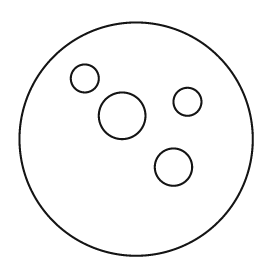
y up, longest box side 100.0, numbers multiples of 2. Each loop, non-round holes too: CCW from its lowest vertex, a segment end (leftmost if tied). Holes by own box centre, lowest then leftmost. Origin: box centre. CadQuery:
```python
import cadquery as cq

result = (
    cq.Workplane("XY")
    .moveTo(0.0, 0.0)
    .circle(50.0)
    .moveTo(16.0, -12.0)
    .circle(8.0)
    .moveTo(-6.0, 10.0)
    .circle(10.0)
    .moveTo(22.0, 16.0)
    .circle(6.0)
    .moveTo(-22.0, 26.0)
    .circle(6.0)
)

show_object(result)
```